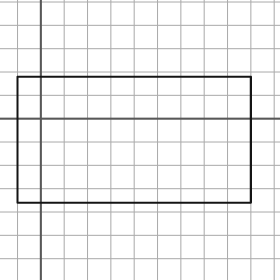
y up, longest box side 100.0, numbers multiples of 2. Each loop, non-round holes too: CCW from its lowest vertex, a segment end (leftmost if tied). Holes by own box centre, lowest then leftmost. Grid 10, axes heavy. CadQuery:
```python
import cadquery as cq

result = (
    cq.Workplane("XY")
    .moveTo(-10.0, -36.0)
    .lineTo(90.0, -36.0)
    .lineTo(90.0, 18.0)
    .lineTo(-10.0, 18.0)
    .close()
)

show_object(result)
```